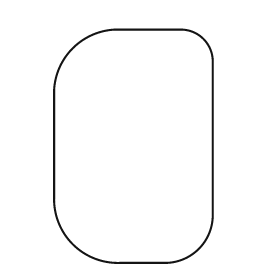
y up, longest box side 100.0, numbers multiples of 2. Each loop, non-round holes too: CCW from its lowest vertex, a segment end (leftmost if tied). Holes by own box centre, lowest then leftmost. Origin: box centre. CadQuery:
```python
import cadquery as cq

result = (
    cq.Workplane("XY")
    .moveTo(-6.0, -50.0)
    .lineTo(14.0, -50.0)
    .threePointArc((28.0, -44.0), (34.0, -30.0))
    .lineTo(34.0, 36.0)
    .threePointArc((30.0, 46.0), (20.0, 50.0))
    .lineTo(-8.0, 50.0)
    .threePointArc((-26.0, 42.0), (-34.0, 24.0))
    .lineTo(-34.0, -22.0)
    .threePointArc((-26.0, -42.0), (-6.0, -50.0))
    .close()
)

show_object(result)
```